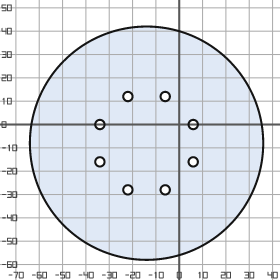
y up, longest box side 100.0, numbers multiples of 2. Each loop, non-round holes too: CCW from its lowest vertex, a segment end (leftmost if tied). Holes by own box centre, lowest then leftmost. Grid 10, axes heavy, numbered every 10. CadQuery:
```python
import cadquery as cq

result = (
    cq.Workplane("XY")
    .moveTo(-14.0, -8.0)
    .circle(50.0)
    .moveTo(-22.0, -28.0)
    .circle(2.0)
    .moveTo(-6.0, -28.0)
    .circle(2.0)
    .moveTo(-34.0, -16.0)
    .circle(2.0)
    .moveTo(6.0, -16.0)
    .circle(2.0)
    .moveTo(-34.0, 0.0)
    .circle(2.0)
    .moveTo(6.0, 0.0)
    .circle(2.0)
    .moveTo(-22.0, 12.0)
    .circle(2.0)
    .moveTo(-6.0, 12.0)
    .circle(2.0)
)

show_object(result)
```